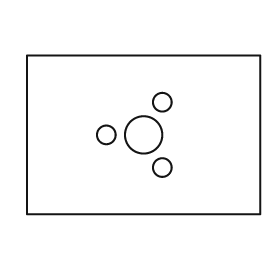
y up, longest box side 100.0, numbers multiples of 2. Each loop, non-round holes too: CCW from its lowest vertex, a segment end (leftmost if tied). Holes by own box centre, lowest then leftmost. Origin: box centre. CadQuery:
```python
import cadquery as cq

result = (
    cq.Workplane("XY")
    .moveTo(-50.0, -34.0)
    .lineTo(50.0, -34.0)
    .lineTo(50.0, 34.0)
    .lineTo(-50.0, 34.0)
    .close()
    .moveTo(8.0, -14.0)
    .circle(4.0)
    .moveTo(-16.0, 0.0)
    .circle(4.0)
    .moveTo(0.0, 0.0)
    .circle(8.0)
    .moveTo(8.0, 14.0)
    .circle(4.0)
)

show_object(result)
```